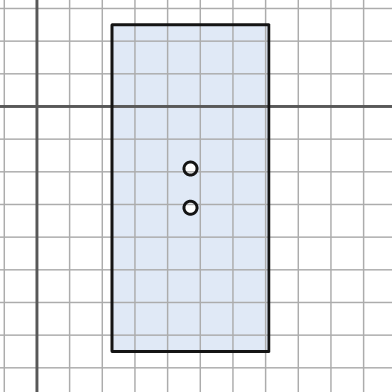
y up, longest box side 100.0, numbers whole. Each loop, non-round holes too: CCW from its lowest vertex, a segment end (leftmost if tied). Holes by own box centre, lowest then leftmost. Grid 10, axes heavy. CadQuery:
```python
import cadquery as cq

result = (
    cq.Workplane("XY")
    .moveTo(23.0, -75.0)
    .lineTo(71.0, -75.0)
    .lineTo(71.0, 25.0)
    .lineTo(23.0, 25.0)
    .close()
    .moveTo(47.0, -31.0)
    .circle(2.0)
    .moveTo(47.0, -19.0)
    .circle(2.0)
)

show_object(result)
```